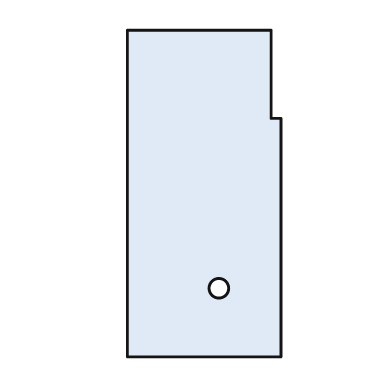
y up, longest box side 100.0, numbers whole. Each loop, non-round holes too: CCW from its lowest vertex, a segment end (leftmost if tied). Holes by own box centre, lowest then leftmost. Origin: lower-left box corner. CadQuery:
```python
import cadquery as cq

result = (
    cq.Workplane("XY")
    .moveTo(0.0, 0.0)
    .lineTo(47.0, 0.0)
    .lineTo(47.0, 73.0)
    .lineTo(44.0, 73.0)
    .lineTo(44.0, 100.0)
    .lineTo(0.0, 100.0)
    .close()
    .moveTo(28.0, 21.0)
    .circle(3.0)
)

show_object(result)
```